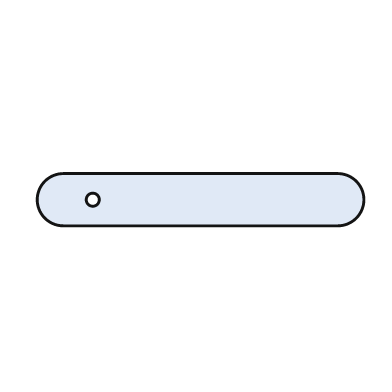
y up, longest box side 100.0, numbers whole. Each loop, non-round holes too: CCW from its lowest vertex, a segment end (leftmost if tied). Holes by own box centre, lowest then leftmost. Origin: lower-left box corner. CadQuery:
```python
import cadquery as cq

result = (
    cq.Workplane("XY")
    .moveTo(8.0, 0.0)
    .lineTo(92.0, 0.0)
    .threePointArc((100.0, 8.0), (92.0, 16.0))
    .lineTo(8.0, 16.0)
    .threePointArc((0.0, 8.0), (8.0, 0.0))
    .close()
    .moveTo(17.0, 8.0)
    .circle(2.0)
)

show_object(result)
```